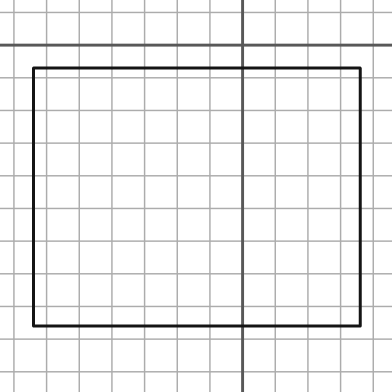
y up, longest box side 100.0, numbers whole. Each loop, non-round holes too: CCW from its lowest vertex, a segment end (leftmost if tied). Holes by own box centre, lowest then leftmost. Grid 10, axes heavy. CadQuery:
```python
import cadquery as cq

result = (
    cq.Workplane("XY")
    .moveTo(-64.0, -86.0)
    .lineTo(36.0, -86.0)
    .lineTo(36.0, -7.0)
    .lineTo(-64.0, -7.0)
    .close()
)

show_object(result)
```